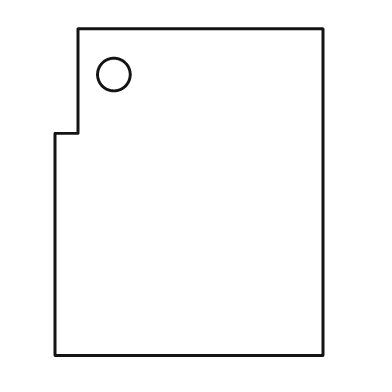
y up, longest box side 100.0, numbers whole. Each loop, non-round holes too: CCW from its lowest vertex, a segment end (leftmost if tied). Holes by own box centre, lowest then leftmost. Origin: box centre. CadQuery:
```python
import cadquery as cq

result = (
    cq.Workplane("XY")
    .moveTo(-41.0, -50.0)
    .lineTo(41.0, -50.0)
    .lineTo(41.0, 50.0)
    .lineTo(-34.0, 50.0)
    .lineTo(-34.0, 18.0)
    .lineTo(-41.0, 18.0)
    .close()
    .moveTo(-23.0, 36.0)
    .circle(5.0)
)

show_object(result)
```